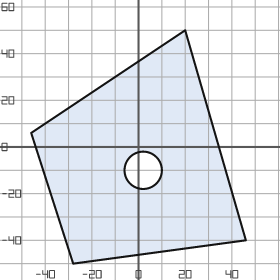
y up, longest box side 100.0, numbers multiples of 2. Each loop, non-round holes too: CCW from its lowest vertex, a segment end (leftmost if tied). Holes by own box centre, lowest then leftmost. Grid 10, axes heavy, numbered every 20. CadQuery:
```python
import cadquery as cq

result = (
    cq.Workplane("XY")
    .moveTo(-28.0, -50.0)
    .lineTo(46.0, -40.0)
    .lineTo(20.0, 50.0)
    .lineTo(-46.0, 6.0)
    .close()
    .moveTo(2.0, -10.0)
    .circle(8.0)
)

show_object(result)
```